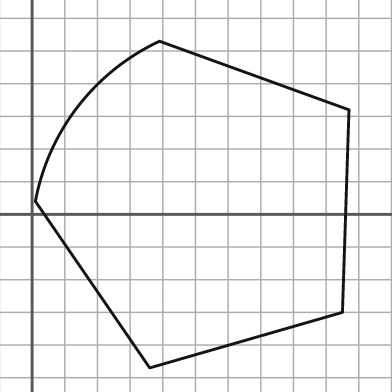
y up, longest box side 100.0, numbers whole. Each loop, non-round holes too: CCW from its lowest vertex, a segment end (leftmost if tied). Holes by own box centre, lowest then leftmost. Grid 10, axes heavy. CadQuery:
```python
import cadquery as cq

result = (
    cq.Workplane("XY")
    .moveTo(36.0, -47.0)
    .lineTo(95.0, -30.0)
    .lineTo(97.0, 32.0)
    .lineTo(39.0, 53.0)
    .threePointArc((14.0, 33.0), (1.0, 4.0))
    .close()
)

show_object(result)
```